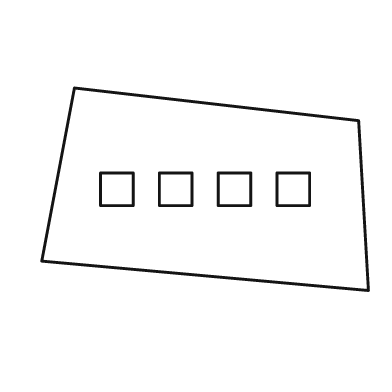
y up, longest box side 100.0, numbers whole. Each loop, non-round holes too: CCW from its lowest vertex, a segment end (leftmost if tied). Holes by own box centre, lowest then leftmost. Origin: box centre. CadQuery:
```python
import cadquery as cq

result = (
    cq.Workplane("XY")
    .moveTo(50.0, -31.0)
    .lineTo(47.0, 21.0)
    .lineTo(-40.0, 31.0)
    .lineTo(-50.0, -22.0)
    .close()
    .moveTo(-32.0, -5.0)
    .lineTo(-22.0, -5.0)
    .lineTo(-22.0, 5.0)
    .lineTo(-32.0, 5.0)
    .close()
    .moveTo(-14.0, -5.0)
    .lineTo(-4.0, -5.0)
    .lineTo(-4.0, 5.0)
    .lineTo(-14.0, 5.0)
    .close()
    .moveTo(4.0, -5.0)
    .lineTo(14.0, -5.0)
    .lineTo(14.0, 5.0)
    .lineTo(4.0, 5.0)
    .close()
    .moveTo(22.0, -5.0)
    .lineTo(32.0, -5.0)
    .lineTo(32.0, 5.0)
    .lineTo(22.0, 5.0)
    .close()
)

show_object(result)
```